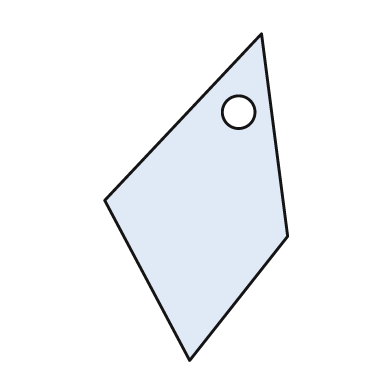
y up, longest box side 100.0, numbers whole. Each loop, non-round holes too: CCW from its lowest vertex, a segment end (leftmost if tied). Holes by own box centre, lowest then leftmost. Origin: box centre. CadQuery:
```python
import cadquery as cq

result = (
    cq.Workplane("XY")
    .moveTo(-2.0, -50.0)
    .lineTo(28.0, -12.0)
    .lineTo(20.0, 50.0)
    .lineTo(-28.0, -1.0)
    .close()
    .moveTo(13.0, 26.0)
    .circle(5.0)
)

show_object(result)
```